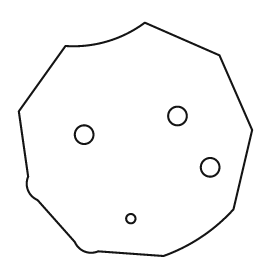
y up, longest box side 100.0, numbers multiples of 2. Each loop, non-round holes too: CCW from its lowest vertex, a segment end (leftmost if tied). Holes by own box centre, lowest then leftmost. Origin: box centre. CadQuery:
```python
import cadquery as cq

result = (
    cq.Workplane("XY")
    .moveTo(12.0, -50.0)
    .threePointArc((28.0, -42.0), (42.0, -30.0))
    .lineTo(50.0, 4.0)
    .lineTo(36.0, 36.0)
    .lineTo(4.0, 50.0)
    .threePointArc((-12.0, 42.0), (-30.0, 40.0))
    .lineTo(-50.0, 12.0)
    .lineTo(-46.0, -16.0)
    .threePointArc((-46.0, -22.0), (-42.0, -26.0))
    .lineTo(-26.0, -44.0)
    .threePointArc((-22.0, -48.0), (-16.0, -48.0))
    .close()
    .moveTo(-2.0, -34.0)
    .circle(2.0)
    .moveTo(32.0, -12.0)
    .circle(4.0)
    .moveTo(-22.0, 2.0)
    .circle(4.0)
    .moveTo(18.0, 10.0)
    .circle(4.0)
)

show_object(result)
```